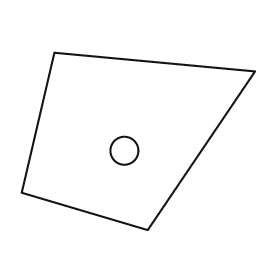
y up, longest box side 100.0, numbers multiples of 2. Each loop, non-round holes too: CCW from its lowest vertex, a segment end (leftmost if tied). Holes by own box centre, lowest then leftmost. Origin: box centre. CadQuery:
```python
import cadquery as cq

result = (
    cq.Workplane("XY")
    .moveTo(4.0, -38.0)
    .lineTo(50.0, 30.0)
    .lineTo(-36.0, 38.0)
    .lineTo(-50.0, -22.0)
    .close()
    .moveTo(-6.0, -4.0)
    .circle(6.0)
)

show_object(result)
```